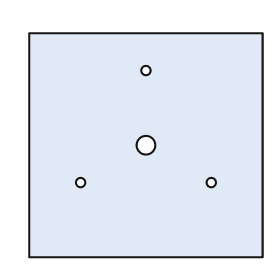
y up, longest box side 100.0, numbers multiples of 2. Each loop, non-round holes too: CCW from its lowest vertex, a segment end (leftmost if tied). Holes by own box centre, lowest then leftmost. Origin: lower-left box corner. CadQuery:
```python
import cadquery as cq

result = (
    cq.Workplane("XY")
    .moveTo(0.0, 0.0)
    .lineTo(100.0, 0.0)
    .lineTo(100.0, 96.0)
    .lineTo(0.0, 96.0)
    .close()
    .moveTo(22.0, 32.0)
    .circle(2.0)
    .moveTo(78.0, 32.0)
    .circle(2.0)
    .moveTo(50.0, 48.0)
    .circle(4.0)
    .moveTo(50.0, 80.0)
    .circle(2.0)
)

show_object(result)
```